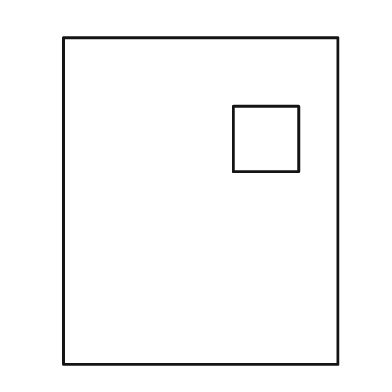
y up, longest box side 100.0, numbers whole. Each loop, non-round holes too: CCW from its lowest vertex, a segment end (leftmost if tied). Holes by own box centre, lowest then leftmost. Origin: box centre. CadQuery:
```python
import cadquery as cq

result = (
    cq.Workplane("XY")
    .moveTo(-42.0, -50.0)
    .lineTo(42.0, -50.0)
    .lineTo(42.0, 50.0)
    .lineTo(-42.0, 50.0)
    .close()
    .moveTo(10.0, 9.0)
    .lineTo(30.0, 9.0)
    .lineTo(30.0, 29.0)
    .lineTo(10.0, 29.0)
    .close()
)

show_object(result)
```